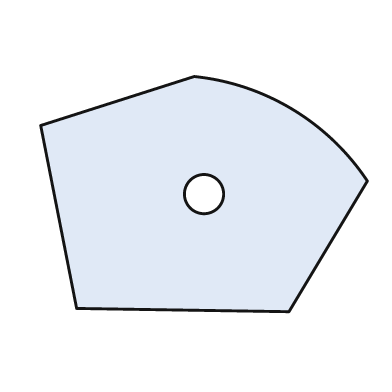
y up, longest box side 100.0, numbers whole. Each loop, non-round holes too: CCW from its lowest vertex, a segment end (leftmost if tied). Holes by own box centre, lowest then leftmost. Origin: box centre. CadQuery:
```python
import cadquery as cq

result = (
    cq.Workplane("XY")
    .moveTo(26.0, -36.0)
    .lineTo(50.0, 4.0)
    .threePointArc((27.0, 26.0), (-3.0, 36.0))
    .lineTo(-50.0, 21.0)
    .lineTo(-39.0, -35.0)
    .close()
    .moveTo(0.0, 0.0)
    .circle(6.0)
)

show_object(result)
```